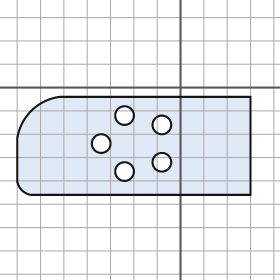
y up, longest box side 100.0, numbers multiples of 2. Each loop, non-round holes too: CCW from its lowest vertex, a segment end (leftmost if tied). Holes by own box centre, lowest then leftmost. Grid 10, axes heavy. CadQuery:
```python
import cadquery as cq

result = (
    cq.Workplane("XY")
    .moveTo(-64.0, -46.0)
    .lineTo(30.0, -46.0)
    .lineTo(30.0, -4.0)
    .lineTo(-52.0, -4.0)
    .threePointArc((-64.0, -10.0), (-70.0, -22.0))
    .lineTo(-70.0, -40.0)
    .threePointArc((-68.0, -44.0), (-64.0, -46.0))
    .close()
    .moveTo(-24.0, -36.0)
    .circle(4.0)
    .moveTo(-8.0, -32.0)
    .circle(4.0)
    .moveTo(-34.0, -24.0)
    .circle(4.0)
    .moveTo(-8.0, -16.0)
    .circle(4.0)
    .moveTo(-24.0, -12.0)
    .circle(4.0)
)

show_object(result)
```